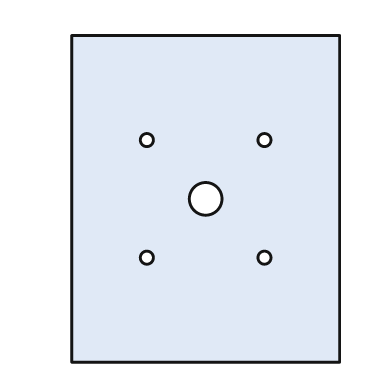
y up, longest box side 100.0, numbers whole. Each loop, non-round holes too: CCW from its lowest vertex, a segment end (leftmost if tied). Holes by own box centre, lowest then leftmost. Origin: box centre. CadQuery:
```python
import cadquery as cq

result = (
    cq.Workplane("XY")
    .moveTo(-41.0, -50.0)
    .lineTo(41.0, -50.0)
    .lineTo(41.0, 50.0)
    .lineTo(-41.0, 50.0)
    .close()
    .moveTo(-18.0, -18.0)
    .circle(2.0)
    .moveTo(18.0, -18.0)
    .circle(2.0)
    .moveTo(0.0, 0.0)
    .circle(5.0)
    .moveTo(-18.0, 18.0)
    .circle(2.0)
    .moveTo(18.0, 18.0)
    .circle(2.0)
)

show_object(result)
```